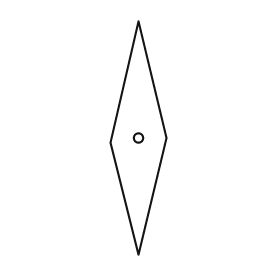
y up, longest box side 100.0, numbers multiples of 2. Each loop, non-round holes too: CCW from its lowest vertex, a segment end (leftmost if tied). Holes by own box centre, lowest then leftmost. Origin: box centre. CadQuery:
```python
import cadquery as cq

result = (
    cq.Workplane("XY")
    .moveTo(0.0, -50.0)
    .lineTo(12.0, 0.0)
    .lineTo(0.0, 50.0)
    .lineTo(-12.0, -2.0)
    .close()
    .moveTo(0.0, 0.0)
    .circle(2.0)
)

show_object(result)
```